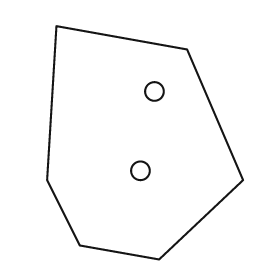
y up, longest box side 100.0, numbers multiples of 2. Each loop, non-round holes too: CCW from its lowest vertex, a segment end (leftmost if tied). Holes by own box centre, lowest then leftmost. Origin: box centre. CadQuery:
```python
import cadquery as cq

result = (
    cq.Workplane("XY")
    .moveTo(6.0, -50.0)
    .lineTo(42.0, -16.0)
    .lineTo(18.0, 40.0)
    .lineTo(-38.0, 50.0)
    .lineTo(-42.0, -16.0)
    .lineTo(-28.0, -44.0)
    .close()
    .moveTo(-2.0, -12.0)
    .circle(4.0)
    .moveTo(4.0, 22.0)
    .circle(4.0)
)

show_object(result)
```